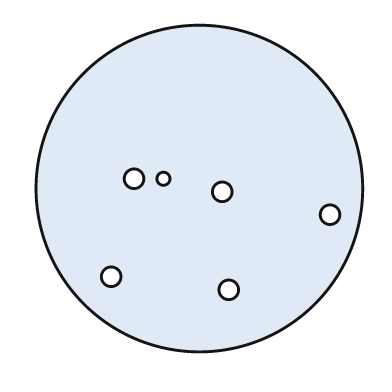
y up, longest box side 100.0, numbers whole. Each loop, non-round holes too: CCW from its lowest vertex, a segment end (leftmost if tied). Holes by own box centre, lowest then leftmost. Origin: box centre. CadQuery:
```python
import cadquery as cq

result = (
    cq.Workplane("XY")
    .moveTo(0.0, 0.0)
    .circle(50.0)
    .moveTo(9.0, -31.0)
    .circle(3.0)
    .moveTo(-27.0, -27.0)
    .circle(3.0)
    .moveTo(40.0, -8.0)
    .circle(3.0)
    .moveTo(7.0, -1.0)
    .circle(3.0)
    .moveTo(-20.0, 3.0)
    .circle(3.0)
    .moveTo(-11.0, 3.0)
    .circle(2.0)
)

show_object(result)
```